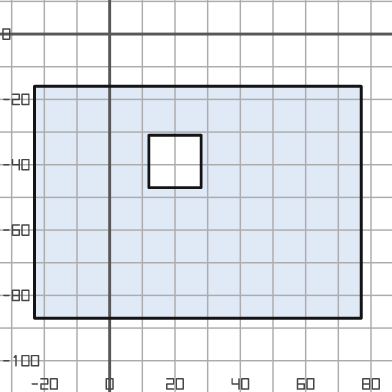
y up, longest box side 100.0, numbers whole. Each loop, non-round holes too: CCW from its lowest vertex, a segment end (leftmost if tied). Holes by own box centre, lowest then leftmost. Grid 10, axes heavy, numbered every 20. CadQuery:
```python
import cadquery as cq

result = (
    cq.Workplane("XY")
    .moveTo(-23.0, -87.0)
    .lineTo(77.0, -87.0)
    .lineTo(77.0, -16.0)
    .lineTo(-23.0, -16.0)
    .close()
    .moveTo(12.0, -47.0)
    .lineTo(28.0, -47.0)
    .lineTo(28.0, -31.0)
    .lineTo(12.0, -31.0)
    .close()
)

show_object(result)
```